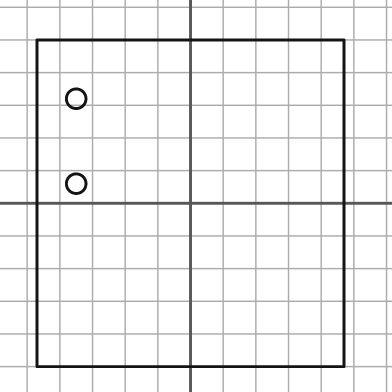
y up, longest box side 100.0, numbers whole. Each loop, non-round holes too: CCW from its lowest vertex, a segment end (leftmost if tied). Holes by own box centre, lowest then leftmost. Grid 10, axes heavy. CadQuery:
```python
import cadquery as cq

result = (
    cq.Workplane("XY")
    .moveTo(-47.0, -50.0)
    .lineTo(47.0, -50.0)
    .lineTo(47.0, 50.0)
    .lineTo(-47.0, 50.0)
    .close()
    .moveTo(-35.0, 6.0)
    .circle(3.0)
    .moveTo(-35.0, 32.0)
    .circle(3.0)
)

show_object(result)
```